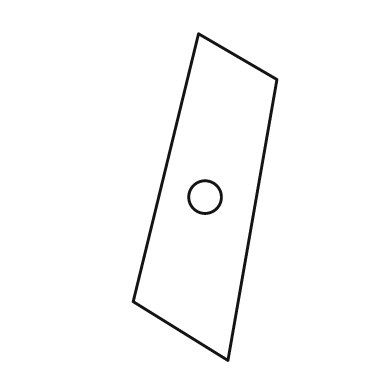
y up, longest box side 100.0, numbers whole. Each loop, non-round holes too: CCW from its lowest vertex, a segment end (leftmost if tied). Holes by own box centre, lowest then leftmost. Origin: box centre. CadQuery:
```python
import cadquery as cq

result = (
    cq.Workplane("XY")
    .moveTo(7.0, -50.0)
    .lineTo(22.0, 36.0)
    .lineTo(-2.0, 50.0)
    .lineTo(-22.0, -32.0)
    .close()
    .moveTo(0.0, 0.0)
    .circle(5.0)
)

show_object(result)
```